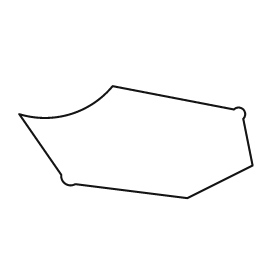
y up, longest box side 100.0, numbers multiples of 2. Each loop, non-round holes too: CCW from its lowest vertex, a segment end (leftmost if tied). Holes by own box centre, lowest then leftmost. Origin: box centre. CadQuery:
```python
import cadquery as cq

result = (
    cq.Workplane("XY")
    .moveTo(22.0, -24.0)
    .lineTo(50.0, -10.0)
    .lineTo(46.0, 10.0)
    .threePointArc((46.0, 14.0), (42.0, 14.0))
    .lineTo(-10.0, 24.0)
    .threePointArc((-28.0, 12.0), (-50.0, 12.0))
    .lineTo(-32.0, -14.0)
    .threePointArc((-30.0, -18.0), (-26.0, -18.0))
    .close()
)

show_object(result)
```